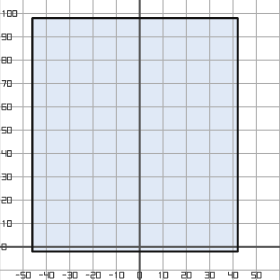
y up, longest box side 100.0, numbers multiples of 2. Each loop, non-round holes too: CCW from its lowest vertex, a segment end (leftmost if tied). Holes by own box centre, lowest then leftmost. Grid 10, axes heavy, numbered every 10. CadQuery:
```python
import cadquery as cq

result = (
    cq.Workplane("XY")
    .moveTo(-46.0, -2.0)
    .lineTo(42.0, -2.0)
    .lineTo(42.0, 98.0)
    .lineTo(-46.0, 98.0)
    .close()
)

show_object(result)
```